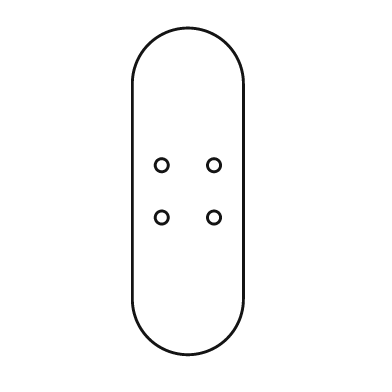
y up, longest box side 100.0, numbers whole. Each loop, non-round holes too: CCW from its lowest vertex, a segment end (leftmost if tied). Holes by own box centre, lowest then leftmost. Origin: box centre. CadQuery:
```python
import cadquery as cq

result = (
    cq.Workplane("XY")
    .moveTo(-17.0, -33.0)
    .threePointArc((0.0, -50.0), (17.0, -33.0))
    .lineTo(17.0, 33.0)
    .threePointArc((0.0, 50.0), (-17.0, 33.0))
    .close()
    .moveTo(-8.0, -8.0)
    .circle(2.0)
    .moveTo(8.0, -8.0)
    .circle(2.0)
    .moveTo(-8.0, 8.0)
    .circle(2.0)
    .moveTo(8.0, 8.0)
    .circle(2.0)
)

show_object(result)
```